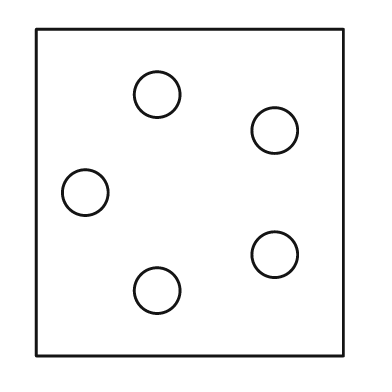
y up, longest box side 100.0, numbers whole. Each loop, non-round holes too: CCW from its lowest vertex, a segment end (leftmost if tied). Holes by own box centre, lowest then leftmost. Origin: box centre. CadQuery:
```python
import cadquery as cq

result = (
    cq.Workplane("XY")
    .moveTo(-47.0, -50.0)
    .lineTo(47.0, -50.0)
    .lineTo(47.0, 50.0)
    .lineTo(-47.0, 50.0)
    .close()
    .moveTo(-10.0, -30.0)
    .circle(7.0)
    .moveTo(26.0, -19.0)
    .circle(7.0)
    .moveTo(-32.0, 0.0)
    .circle(7.0)
    .moveTo(26.0, 19.0)
    .circle(7.0)
    .moveTo(-10.0, 30.0)
    .circle(7.0)
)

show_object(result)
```